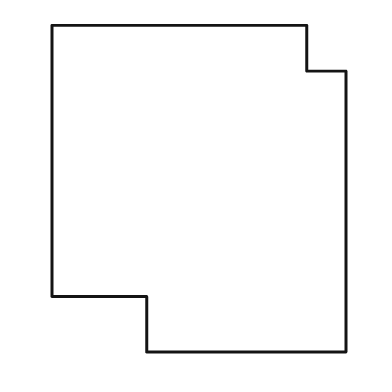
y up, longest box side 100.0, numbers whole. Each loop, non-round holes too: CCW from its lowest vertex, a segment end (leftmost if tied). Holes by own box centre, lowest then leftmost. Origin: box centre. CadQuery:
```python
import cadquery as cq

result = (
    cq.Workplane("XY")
    .moveTo(-16.0, -50.0)
    .lineTo(45.0, -50.0)
    .lineTo(45.0, 36.0)
    .lineTo(33.0, 36.0)
    .lineTo(33.0, 50.0)
    .lineTo(-45.0, 50.0)
    .lineTo(-45.0, -33.0)
    .lineTo(-16.0, -33.0)
    .close()
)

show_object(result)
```